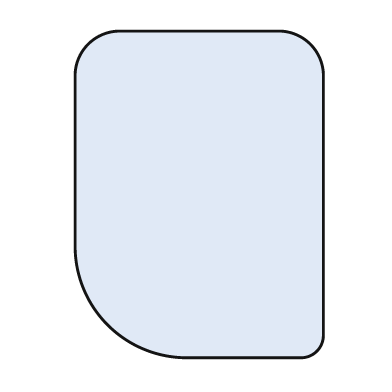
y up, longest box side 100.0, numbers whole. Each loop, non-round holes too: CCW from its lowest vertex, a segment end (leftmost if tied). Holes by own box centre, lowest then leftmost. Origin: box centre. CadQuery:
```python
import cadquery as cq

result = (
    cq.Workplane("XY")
    .moveTo(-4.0, -50.0)
    .lineTo(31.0, -50.0)
    .threePointArc((36.0, -48.0), (38.0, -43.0))
    .lineTo(38.0, 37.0)
    .threePointArc((34.0, 46.0), (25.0, 50.0))
    .lineTo(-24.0, 50.0)
    .threePointArc((-34.0, 46.0), (-38.0, 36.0))
    .lineTo(-38.0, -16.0)
    .threePointArc((-28.0, -40.0), (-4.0, -50.0))
    .close()
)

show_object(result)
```